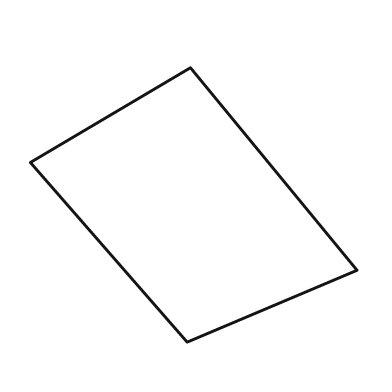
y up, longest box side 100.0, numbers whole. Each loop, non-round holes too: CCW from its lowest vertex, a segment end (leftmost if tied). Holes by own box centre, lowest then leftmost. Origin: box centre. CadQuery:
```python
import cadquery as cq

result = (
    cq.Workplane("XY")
    .moveTo(-2.0, -42.0)
    .lineTo(50.0, -20.0)
    .lineTo(-1.0, 42.0)
    .lineTo(-50.0, 13.0)
    .close()
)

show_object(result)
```